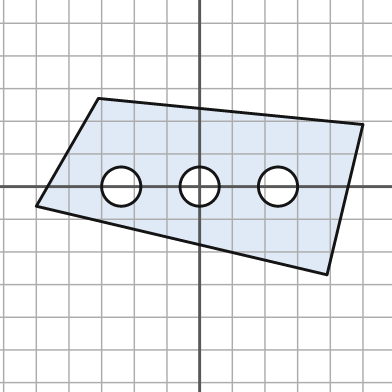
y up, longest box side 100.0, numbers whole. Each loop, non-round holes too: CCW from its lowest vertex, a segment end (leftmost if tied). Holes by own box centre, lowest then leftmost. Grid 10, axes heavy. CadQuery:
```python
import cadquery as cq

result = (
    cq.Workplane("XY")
    .moveTo(39.0, -27.0)
    .lineTo(50.0, 19.0)
    .lineTo(-31.0, 27.0)
    .lineTo(-50.0, -6.0)
    .close()
    .moveTo(-24.0, 0.0)
    .circle(6.0)
    .moveTo(0.0, 0.0)
    .circle(6.0)
    .moveTo(24.0, 0.0)
    .circle(6.0)
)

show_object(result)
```